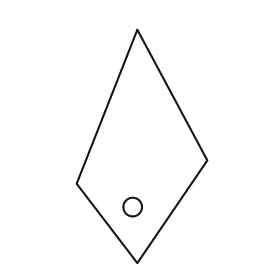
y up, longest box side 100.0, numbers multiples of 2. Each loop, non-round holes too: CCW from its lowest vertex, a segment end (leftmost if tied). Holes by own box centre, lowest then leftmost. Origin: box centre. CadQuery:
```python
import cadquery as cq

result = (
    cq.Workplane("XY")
    .moveTo(-2.0, -50.0)
    .lineTo(28.0, -6.0)
    .lineTo(-2.0, 50.0)
    .lineTo(-28.0, -16.0)
    .close()
    .moveTo(-4.0, -26.0)
    .circle(4.0)
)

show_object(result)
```